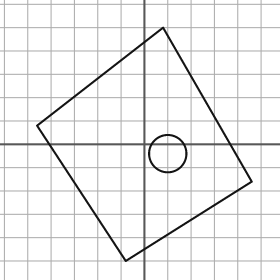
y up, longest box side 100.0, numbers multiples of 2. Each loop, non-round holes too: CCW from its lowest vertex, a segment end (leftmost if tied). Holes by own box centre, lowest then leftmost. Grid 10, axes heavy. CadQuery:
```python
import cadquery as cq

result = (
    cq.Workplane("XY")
    .moveTo(-8.0, -50.0)
    .lineTo(46.0, -16.0)
    .lineTo(8.0, 50.0)
    .lineTo(-46.0, 8.0)
    .close()
    .moveTo(10.0, -4.0)
    .circle(8.0)
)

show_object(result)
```